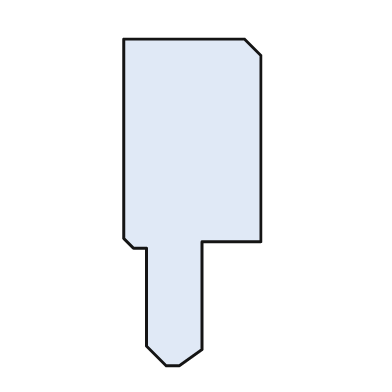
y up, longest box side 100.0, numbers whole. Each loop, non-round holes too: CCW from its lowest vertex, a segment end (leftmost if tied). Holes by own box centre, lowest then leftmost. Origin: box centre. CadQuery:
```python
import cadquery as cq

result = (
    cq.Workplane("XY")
    .moveTo(-8.0, -50.0)
    .lineTo(-4.0, -50.0)
    .lineTo(3.0, -45.0)
    .lineTo(3.0, -12.0)
    .lineTo(21.0, -12.0)
    .lineTo(21.0, 45.0)
    .lineTo(16.0, 50.0)
    .lineTo(-21.0, 50.0)
    .lineTo(-21.0, -11.0)
    .lineTo(-18.0, -14.0)
    .lineTo(-14.0, -14.0)
    .lineTo(-14.0, -44.0)
    .close()
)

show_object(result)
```